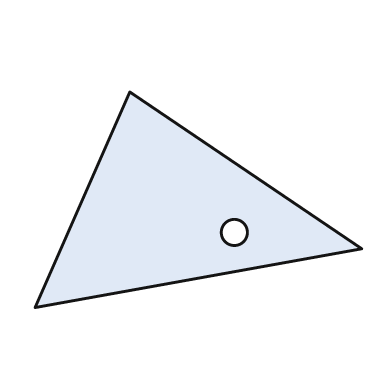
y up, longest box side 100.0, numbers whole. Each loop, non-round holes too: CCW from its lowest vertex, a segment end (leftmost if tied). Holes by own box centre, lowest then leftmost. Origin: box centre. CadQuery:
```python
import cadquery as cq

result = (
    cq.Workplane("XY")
    .moveTo(-50.0, -33.0)
    .lineTo(50.0, -15.0)
    .lineTo(-21.0, 33.0)
    .close()
    .moveTo(11.0, -10.0)
    .circle(4.0)
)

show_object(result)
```